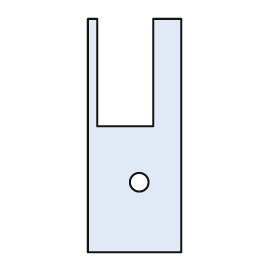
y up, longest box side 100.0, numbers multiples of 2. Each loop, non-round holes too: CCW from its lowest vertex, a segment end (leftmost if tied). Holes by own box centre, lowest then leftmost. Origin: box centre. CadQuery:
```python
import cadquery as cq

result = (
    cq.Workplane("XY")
    .moveTo(-20.0, -50.0)
    .lineTo(20.0, -50.0)
    .lineTo(20.0, 50.0)
    .lineTo(8.0, 50.0)
    .lineTo(8.0, 4.0)
    .lineTo(-16.0, 4.0)
    .lineTo(-16.0, 50.0)
    .lineTo(-20.0, 50.0)
    .close()
    .moveTo(2.0, -20.0)
    .circle(4.0)
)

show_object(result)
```